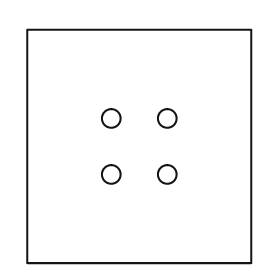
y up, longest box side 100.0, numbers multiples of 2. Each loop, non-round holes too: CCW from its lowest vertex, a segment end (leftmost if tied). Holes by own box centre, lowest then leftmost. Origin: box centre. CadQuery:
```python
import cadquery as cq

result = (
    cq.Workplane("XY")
    .moveTo(-48.0, -50.0)
    .lineTo(48.0, -50.0)
    .lineTo(48.0, 50.0)
    .lineTo(-48.0, 50.0)
    .close()
    .moveTo(-12.0, -12.0)
    .circle(4.0)
    .moveTo(12.0, -12.0)
    .circle(4.0)
    .moveTo(-12.0, 12.0)
    .circle(4.0)
    .moveTo(12.0, 12.0)
    .circle(4.0)
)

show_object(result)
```